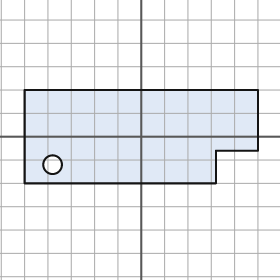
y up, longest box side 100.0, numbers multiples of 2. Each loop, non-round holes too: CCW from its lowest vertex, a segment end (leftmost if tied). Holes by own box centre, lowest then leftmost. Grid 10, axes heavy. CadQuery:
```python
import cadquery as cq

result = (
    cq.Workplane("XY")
    .moveTo(-50.0, -20.0)
    .lineTo(32.0, -20.0)
    .lineTo(32.0, -6.0)
    .lineTo(50.0, -6.0)
    .lineTo(50.0, 20.0)
    .lineTo(-50.0, 20.0)
    .close()
    .moveTo(-38.0, -12.0)
    .circle(4.0)
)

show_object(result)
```